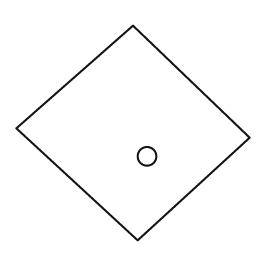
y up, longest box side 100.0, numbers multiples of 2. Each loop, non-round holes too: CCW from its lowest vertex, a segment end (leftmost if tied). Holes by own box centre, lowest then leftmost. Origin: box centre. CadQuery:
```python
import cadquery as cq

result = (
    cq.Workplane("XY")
    .moveTo(2.0, -46.0)
    .lineTo(50.0, -2.0)
    .lineTo(0.0, 46.0)
    .lineTo(-50.0, 2.0)
    .close()
    .moveTo(6.0, -10.0)
    .circle(4.0)
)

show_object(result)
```